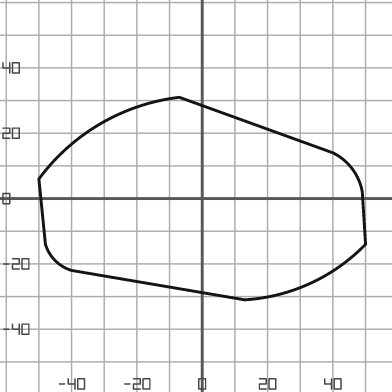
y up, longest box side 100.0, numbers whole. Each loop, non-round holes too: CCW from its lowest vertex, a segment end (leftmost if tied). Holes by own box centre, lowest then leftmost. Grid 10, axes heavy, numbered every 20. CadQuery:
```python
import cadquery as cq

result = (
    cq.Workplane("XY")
    .moveTo(13.0, -31.0)
    .threePointArc((33.0, -26.0), (50.0, -14.0))
    .lineTo(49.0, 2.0)
    .threePointArc((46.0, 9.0), (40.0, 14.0))
    .lineTo(-7.0, 31.0)
    .threePointArc((-31.0, 23.0), (-50.0, 6.0))
    .lineTo(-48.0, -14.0)
    .threePointArc((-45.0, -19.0), (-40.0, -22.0))
    .close()
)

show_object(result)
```